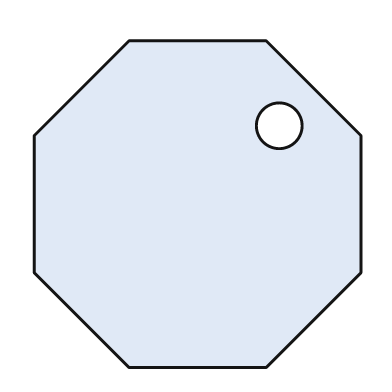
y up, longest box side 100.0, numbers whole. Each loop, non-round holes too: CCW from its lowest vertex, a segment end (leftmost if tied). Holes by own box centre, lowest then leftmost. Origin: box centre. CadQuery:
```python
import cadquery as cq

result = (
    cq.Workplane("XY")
    .moveTo(-21.0, -50.0)
    .lineTo(21.0, -50.0)
    .lineTo(50.0, -21.0)
    .lineTo(50.0, 21.0)
    .lineTo(21.0, 50.0)
    .lineTo(-21.0, 50.0)
    .lineTo(-50.0, 21.0)
    .lineTo(-50.0, -21.0)
    .close()
    .moveTo(25.0, 24.0)
    .circle(7.0)
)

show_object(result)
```